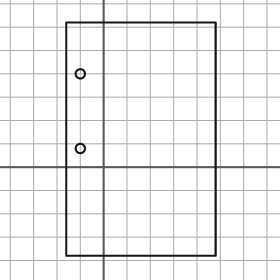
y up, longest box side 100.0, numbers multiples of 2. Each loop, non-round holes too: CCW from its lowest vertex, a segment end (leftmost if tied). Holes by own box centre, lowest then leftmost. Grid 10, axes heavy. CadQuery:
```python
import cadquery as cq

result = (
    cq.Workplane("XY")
    .moveTo(-16.0, -38.0)
    .lineTo(48.0, -38.0)
    .lineTo(48.0, 62.0)
    .lineTo(-16.0, 62.0)
    .close()
    .moveTo(-10.0, 8.0)
    .circle(2.0)
    .moveTo(-10.0, 40.0)
    .circle(2.0)
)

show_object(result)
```